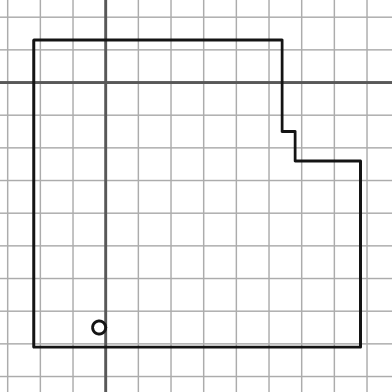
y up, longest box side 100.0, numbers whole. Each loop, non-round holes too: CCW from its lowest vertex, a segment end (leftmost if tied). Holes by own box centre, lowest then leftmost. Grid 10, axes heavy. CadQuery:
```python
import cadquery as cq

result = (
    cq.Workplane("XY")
    .moveTo(-22.0, -81.0)
    .lineTo(78.0, -81.0)
    .lineTo(78.0, -24.0)
    .lineTo(58.0, -24.0)
    .lineTo(58.0, -15.0)
    .lineTo(54.0, -15.0)
    .lineTo(54.0, 13.0)
    .lineTo(-22.0, 13.0)
    .close()
    .moveTo(-2.0, -75.0)
    .circle(2.0)
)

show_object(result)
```